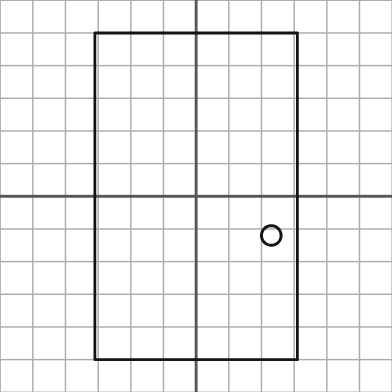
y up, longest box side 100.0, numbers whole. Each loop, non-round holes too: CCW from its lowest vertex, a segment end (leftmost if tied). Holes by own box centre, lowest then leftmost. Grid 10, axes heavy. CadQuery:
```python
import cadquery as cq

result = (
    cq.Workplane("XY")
    .moveTo(-31.0, -50.0)
    .lineTo(31.0, -50.0)
    .lineTo(31.0, 50.0)
    .lineTo(-31.0, 50.0)
    .close()
    .moveTo(23.0, -12.0)
    .circle(3.0)
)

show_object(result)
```